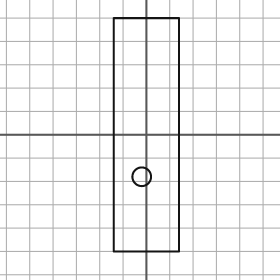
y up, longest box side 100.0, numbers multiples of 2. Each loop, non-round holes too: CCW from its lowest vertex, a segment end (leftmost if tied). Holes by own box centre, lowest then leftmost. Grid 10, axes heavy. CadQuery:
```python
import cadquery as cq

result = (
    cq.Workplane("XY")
    .moveTo(-14.0, -50.0)
    .lineTo(14.0, -50.0)
    .lineTo(14.0, 50.0)
    .lineTo(-14.0, 50.0)
    .close()
    .moveTo(-2.0, -18.0)
    .circle(4.0)
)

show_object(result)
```